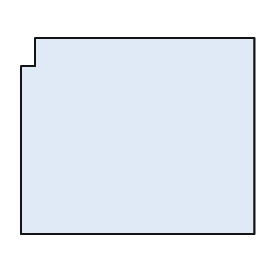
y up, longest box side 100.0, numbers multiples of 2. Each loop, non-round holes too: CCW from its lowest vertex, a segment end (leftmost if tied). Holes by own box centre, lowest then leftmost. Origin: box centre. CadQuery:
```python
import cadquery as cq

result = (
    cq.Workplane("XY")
    .moveTo(-50.0, -42.0)
    .lineTo(50.0, -42.0)
    .lineTo(50.0, 42.0)
    .lineTo(-44.0, 42.0)
    .lineTo(-44.0, 30.0)
    .lineTo(-50.0, 30.0)
    .close()
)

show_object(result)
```